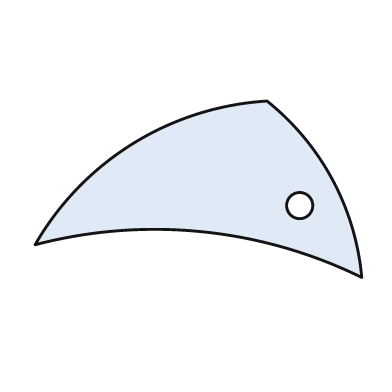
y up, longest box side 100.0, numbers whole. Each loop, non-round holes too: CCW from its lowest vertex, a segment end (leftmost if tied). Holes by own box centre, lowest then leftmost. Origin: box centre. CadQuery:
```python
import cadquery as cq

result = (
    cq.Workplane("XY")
    .moveTo(50.0, -27.0)
    .threePointArc((41.0, 3.0), (21.0, 27.0))
    .threePointArc((-20.0, 14.0), (-50.0, -17.0))
    .threePointArc((1.0, -13.0), (50.0, -27.0))
    .close()
    .moveTo(31.0, -5.0)
    .circle(4.0)
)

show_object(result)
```